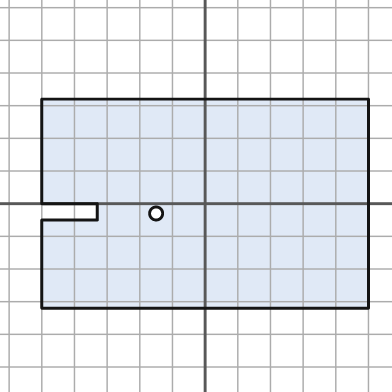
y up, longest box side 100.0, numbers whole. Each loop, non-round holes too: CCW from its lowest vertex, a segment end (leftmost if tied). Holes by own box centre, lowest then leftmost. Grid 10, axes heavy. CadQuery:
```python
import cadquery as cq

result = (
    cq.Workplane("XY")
    .moveTo(-50.0, -32.0)
    .lineTo(50.0, -32.0)
    .lineTo(50.0, 32.0)
    .lineTo(-50.0, 32.0)
    .lineTo(-50.0, 0.0)
    .lineTo(-33.0, 0.0)
    .lineTo(-33.0, -5.0)
    .lineTo(-50.0, -5.0)
    .close()
    .moveTo(-15.0, -3.0)
    .circle(2.0)
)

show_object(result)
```